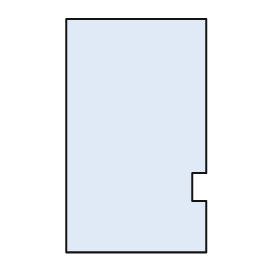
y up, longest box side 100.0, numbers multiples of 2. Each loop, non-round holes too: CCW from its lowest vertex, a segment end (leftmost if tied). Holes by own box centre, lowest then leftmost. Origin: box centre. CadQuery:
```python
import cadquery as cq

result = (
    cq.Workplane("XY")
    .moveTo(-30.0, -50.0)
    .lineTo(30.0, -50.0)
    .lineTo(30.0, -28.0)
    .lineTo(24.0, -28.0)
    .lineTo(24.0, -16.0)
    .lineTo(30.0, -16.0)
    .lineTo(30.0, 50.0)
    .lineTo(-30.0, 50.0)
    .close()
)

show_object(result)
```